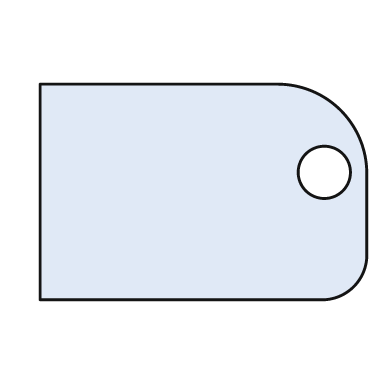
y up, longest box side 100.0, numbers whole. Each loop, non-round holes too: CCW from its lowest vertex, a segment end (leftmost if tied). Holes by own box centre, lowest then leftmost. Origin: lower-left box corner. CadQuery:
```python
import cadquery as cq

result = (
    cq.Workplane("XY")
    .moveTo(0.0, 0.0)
    .lineTo(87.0, 0.0)
    .threePointArc((96.0, 4.0), (100.0, 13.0))
    .lineTo(100.0, 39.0)
    .threePointArc((92.0, 58.0), (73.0, 66.0))
    .lineTo(0.0, 66.0)
    .close()
    .moveTo(87.0, 39.0)
    .circle(8.0)
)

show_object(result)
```